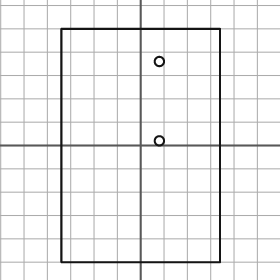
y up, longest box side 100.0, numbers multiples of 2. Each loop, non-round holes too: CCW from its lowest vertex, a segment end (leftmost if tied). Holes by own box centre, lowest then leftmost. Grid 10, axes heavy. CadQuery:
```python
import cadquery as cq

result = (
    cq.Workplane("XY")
    .moveTo(-34.0, -50.0)
    .lineTo(34.0, -50.0)
    .lineTo(34.0, 50.0)
    .lineTo(-34.0, 50.0)
    .close()
    .moveTo(8.0, 2.0)
    .circle(2.0)
    .moveTo(8.0, 36.0)
    .circle(2.0)
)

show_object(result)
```